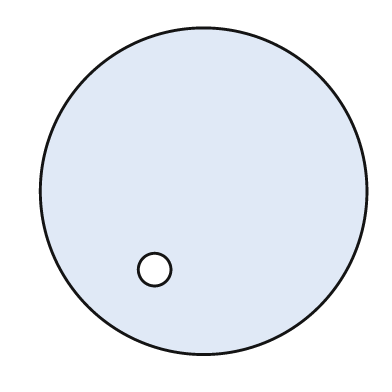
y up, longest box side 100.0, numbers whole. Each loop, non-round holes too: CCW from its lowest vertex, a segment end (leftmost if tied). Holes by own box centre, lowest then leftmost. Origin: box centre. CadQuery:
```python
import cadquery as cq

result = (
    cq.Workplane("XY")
    .moveTo(0.0, 0.0)
    .circle(50.0)
    .moveTo(-15.0, -24.0)
    .circle(5.0)
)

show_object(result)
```